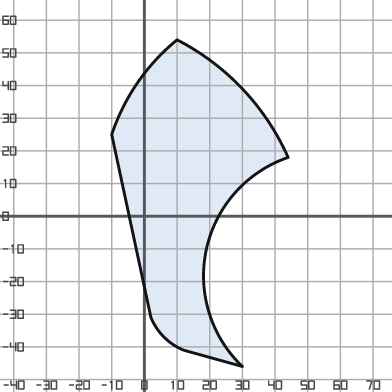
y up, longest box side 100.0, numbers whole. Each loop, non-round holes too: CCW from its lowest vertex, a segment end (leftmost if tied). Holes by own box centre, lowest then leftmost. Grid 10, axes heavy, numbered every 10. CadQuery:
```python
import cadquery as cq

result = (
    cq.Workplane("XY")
    .moveTo(30.0, -46.0)
    .threePointArc((19.0, -10.0), (44.0, 18.0))
    .threePointArc((30.0, 39.0), (10.0, 54.0))
    .threePointArc((-2.0, 41.0), (-10.0, 25.0))
    .lineTo(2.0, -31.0)
    .threePointArc((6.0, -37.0), (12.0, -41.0))
    .close()
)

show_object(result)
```